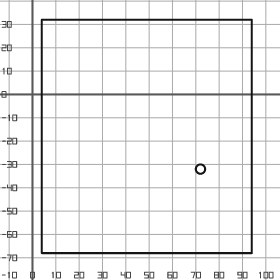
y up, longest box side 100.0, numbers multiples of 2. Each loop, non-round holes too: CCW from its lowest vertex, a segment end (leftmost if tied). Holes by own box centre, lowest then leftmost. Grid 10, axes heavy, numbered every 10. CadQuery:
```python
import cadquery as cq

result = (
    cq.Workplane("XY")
    .moveTo(4.0, -68.0)
    .lineTo(94.0, -68.0)
    .lineTo(94.0, 32.0)
    .lineTo(4.0, 32.0)
    .close()
    .moveTo(72.0, -32.0)
    .circle(2.0)
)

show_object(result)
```